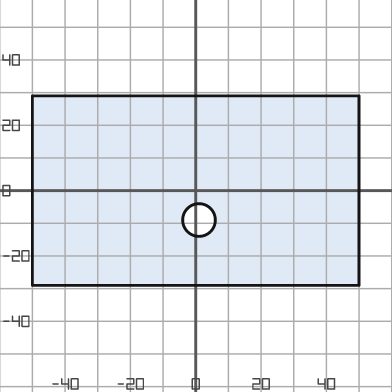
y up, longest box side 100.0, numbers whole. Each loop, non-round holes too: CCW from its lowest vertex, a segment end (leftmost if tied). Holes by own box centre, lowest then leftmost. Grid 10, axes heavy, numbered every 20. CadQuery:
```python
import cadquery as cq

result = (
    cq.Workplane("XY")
    .moveTo(-50.0, -29.0)
    .lineTo(50.0, -29.0)
    .lineTo(50.0, 29.0)
    .lineTo(-50.0, 29.0)
    .close()
    .moveTo(1.0, -9.0)
    .circle(5.0)
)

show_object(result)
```